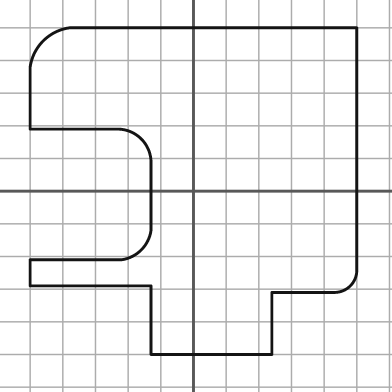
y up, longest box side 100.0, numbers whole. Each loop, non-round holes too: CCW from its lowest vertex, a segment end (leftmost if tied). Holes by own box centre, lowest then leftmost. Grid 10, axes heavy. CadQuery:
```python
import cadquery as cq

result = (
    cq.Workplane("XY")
    .moveTo(-13.0, -50.0)
    .lineTo(24.0, -50.0)
    .lineTo(24.0, -31.0)
    .lineTo(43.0, -31.0)
    .threePointArc((48.0, -29.0), (50.0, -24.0))
    .lineTo(50.0, 50.0)
    .lineTo(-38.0, 50.0)
    .threePointArc((-46.0, 46.0), (-50.0, 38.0))
    .lineTo(-50.0, 19.0)
    .lineTo(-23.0, 19.0)
    .threePointArc((-16.0, 16.0), (-13.0, 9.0))
    .lineTo(-13.0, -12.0)
    .threePointArc((-16.0, -18.0), (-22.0, -21.0))
    .lineTo(-50.0, -21.0)
    .lineTo(-50.0, -29.0)
    .lineTo(-13.0, -29.0)
    .close()
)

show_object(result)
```